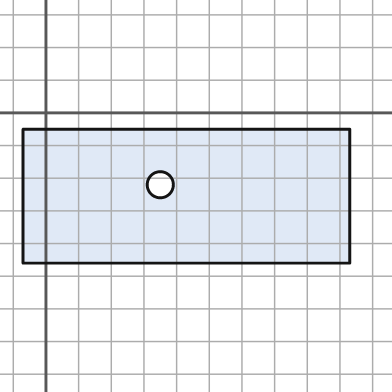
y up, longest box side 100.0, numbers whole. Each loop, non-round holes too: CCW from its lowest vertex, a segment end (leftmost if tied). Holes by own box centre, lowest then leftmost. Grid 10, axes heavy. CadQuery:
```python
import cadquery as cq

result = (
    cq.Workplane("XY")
    .moveTo(-7.0, -46.0)
    .lineTo(93.0, -46.0)
    .lineTo(93.0, -5.0)
    .lineTo(-7.0, -5.0)
    .close()
    .moveTo(35.0, -22.0)
    .circle(4.0)
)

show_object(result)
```